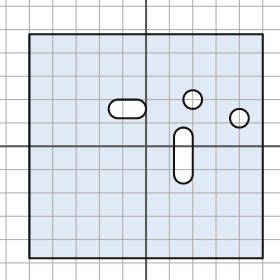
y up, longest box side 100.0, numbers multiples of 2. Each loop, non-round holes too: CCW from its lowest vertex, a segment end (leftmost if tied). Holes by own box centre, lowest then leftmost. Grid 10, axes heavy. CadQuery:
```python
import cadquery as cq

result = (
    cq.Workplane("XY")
    .moveTo(-50.0, -48.0)
    .lineTo(50.0, -48.0)
    .lineTo(50.0, 48.0)
    .lineTo(-50.0, 48.0)
    .close()
    .moveTo(12.0, -12.0)
    .threePointArc((16.0, -16.0), (20.0, -12.0))
    .lineTo(20.0, 4.0)
    .threePointArc((16.0, 8.0), (12.0, 4.0))
    .close()
    .moveTo(40.0, 12.0)
    .circle(4.0)
    .moveTo(-12.0, 12.0)
    .lineTo(-4.0, 12.0)
    .threePointArc((0.0, 16.0), (-4.0, 20.0))
    .lineTo(-12.0, 20.0)
    .threePointArc((-16.0, 16.0), (-12.0, 12.0))
    .close()
    .moveTo(20.0, 20.0)
    .circle(4.0)
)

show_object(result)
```